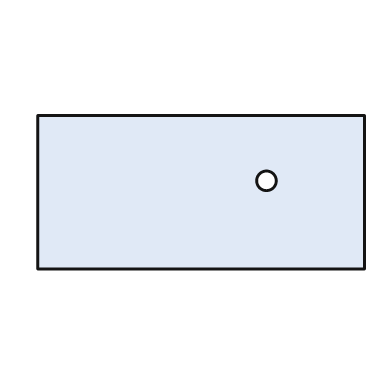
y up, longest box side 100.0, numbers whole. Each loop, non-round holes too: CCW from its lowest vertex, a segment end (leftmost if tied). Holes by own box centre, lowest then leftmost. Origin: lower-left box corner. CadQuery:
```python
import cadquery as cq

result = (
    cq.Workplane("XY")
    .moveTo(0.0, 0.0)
    .lineTo(100.0, 0.0)
    .lineTo(100.0, 47.0)
    .lineTo(0.0, 47.0)
    .close()
    .moveTo(70.0, 27.0)
    .circle(3.0)
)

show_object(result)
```